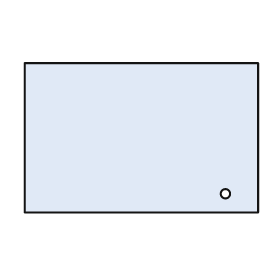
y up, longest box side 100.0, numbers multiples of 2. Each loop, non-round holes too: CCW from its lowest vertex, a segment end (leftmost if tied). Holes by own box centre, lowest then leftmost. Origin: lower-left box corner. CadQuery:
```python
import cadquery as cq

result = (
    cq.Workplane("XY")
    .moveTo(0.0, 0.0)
    .lineTo(100.0, 0.0)
    .lineTo(100.0, 64.0)
    .lineTo(0.0, 64.0)
    .close()
    .moveTo(86.0, 8.0)
    .circle(2.0)
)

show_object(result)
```